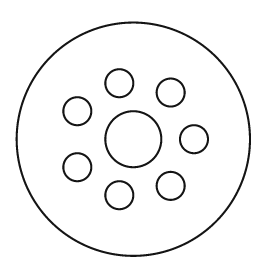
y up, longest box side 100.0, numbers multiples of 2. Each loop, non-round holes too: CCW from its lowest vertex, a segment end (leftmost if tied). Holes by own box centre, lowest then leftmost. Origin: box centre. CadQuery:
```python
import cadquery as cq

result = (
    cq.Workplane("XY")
    .moveTo(0.0, 0.0)
    .circle(50.0)
    .moveTo(-6.0, -24.0)
    .circle(6.0)
    .moveTo(16.0, -20.0)
    .circle(6.0)
    .moveTo(-24.0, -12.0)
    .circle(6.0)
    .moveTo(0.0, 0.0)
    .circle(12.0)
    .moveTo(26.0, 0.0)
    .circle(6.0)
    .moveTo(-24.0, 12.0)
    .circle(6.0)
    .moveTo(16.0, 20.0)
    .circle(6.0)
    .moveTo(-6.0, 24.0)
    .circle(6.0)
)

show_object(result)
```